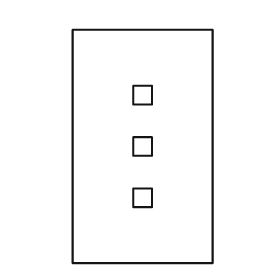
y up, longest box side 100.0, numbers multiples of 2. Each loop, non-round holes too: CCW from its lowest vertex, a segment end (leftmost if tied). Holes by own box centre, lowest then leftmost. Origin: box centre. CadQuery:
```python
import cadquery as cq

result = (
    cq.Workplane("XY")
    .moveTo(-30.0, -50.0)
    .lineTo(30.0, -50.0)
    .lineTo(30.0, 50.0)
    .lineTo(-30.0, 50.0)
    .close()
    .moveTo(-4.0, -26.0)
    .lineTo(4.0, -26.0)
    .lineTo(4.0, -18.0)
    .lineTo(-4.0, -18.0)
    .close()
    .moveTo(-4.0, -4.0)
    .lineTo(4.0, -4.0)
    .lineTo(4.0, 4.0)
    .lineTo(-4.0, 4.0)
    .close()
    .moveTo(-4.0, 18.0)
    .lineTo(4.0, 18.0)
    .lineTo(4.0, 26.0)
    .lineTo(-4.0, 26.0)
    .close()
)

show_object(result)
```